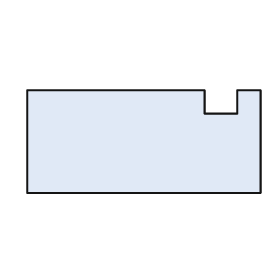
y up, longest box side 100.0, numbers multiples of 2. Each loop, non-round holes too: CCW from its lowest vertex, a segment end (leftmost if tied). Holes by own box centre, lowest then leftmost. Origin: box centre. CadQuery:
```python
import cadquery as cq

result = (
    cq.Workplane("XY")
    .moveTo(-50.0, -22.0)
    .lineTo(50.0, -22.0)
    .lineTo(50.0, 22.0)
    .lineTo(40.0, 22.0)
    .lineTo(40.0, 12.0)
    .lineTo(26.0, 12.0)
    .lineTo(26.0, 22.0)
    .lineTo(-50.0, 22.0)
    .close()
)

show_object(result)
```